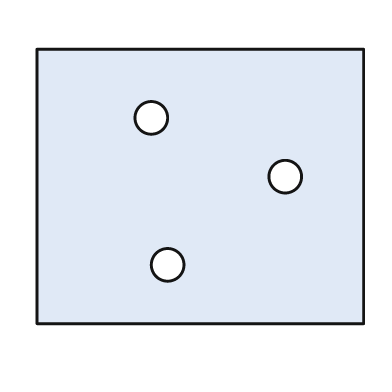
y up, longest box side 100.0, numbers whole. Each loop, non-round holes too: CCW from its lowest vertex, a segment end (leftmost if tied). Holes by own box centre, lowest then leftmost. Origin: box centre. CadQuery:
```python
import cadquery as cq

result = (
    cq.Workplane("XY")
    .moveTo(-50.0, -42.0)
    .lineTo(50.0, -42.0)
    .lineTo(50.0, 42.0)
    .lineTo(-50.0, 42.0)
    .close()
    .moveTo(-10.0, -24.0)
    .circle(5.0)
    .moveTo(26.0, 3.0)
    .circle(5.0)
    .moveTo(-15.0, 21.0)
    .circle(5.0)
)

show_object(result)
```